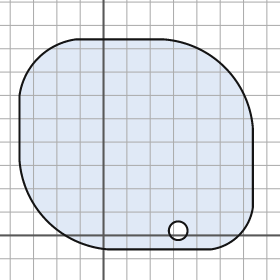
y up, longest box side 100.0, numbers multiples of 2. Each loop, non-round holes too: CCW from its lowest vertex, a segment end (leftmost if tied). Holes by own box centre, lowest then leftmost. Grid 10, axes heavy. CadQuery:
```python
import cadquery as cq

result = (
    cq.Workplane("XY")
    .moveTo(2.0, -6.0)
    .lineTo(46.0, -6.0)
    .threePointArc((58.0, 0.0), (64.0, 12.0))
    .lineTo(64.0, 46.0)
    .threePointArc((52.0, 72.0), (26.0, 84.0))
    .lineTo(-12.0, 84.0)
    .threePointArc((-28.0, 76.0), (-36.0, 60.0))
    .lineTo(-36.0, 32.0)
    .threePointArc((-24.0, 6.0), (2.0, -6.0))
    .close()
    .moveTo(32.0, 2.0)
    .circle(4.0)
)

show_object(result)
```